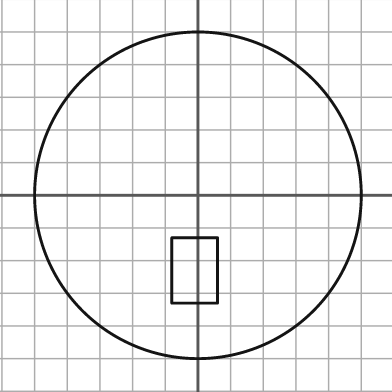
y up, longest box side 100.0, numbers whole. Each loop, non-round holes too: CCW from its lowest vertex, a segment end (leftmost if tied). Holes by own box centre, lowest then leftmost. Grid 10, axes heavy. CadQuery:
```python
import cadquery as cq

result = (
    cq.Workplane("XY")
    .moveTo(0.0, 0.0)
    .circle(50.0)
    .moveTo(-8.0, -33.0)
    .lineTo(6.0, -33.0)
    .lineTo(6.0, -13.0)
    .lineTo(-8.0, -13.0)
    .close()
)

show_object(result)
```